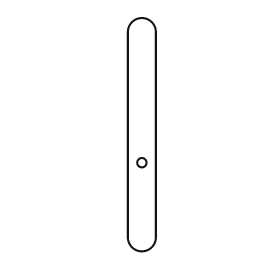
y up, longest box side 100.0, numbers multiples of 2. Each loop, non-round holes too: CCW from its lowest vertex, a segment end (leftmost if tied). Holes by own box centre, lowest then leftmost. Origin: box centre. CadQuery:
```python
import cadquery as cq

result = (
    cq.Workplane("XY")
    .moveTo(-6.0, -44.0)
    .threePointArc((0.0, -50.0), (6.0, -44.0))
    .lineTo(6.0, 44.0)
    .threePointArc((0.0, 50.0), (-6.0, 44.0))
    .close()
    .moveTo(0.0, -12.0)
    .circle(2.0)
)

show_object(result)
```